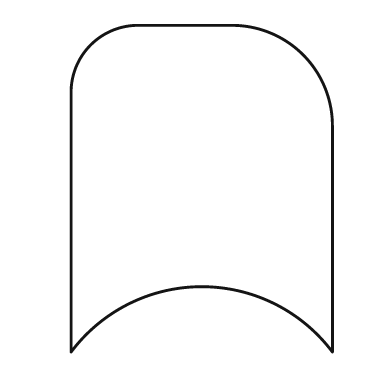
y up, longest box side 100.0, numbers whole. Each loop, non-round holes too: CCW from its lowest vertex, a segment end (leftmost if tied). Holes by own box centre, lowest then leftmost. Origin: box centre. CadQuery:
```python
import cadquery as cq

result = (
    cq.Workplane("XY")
    .moveTo(-40.0, -50.0)
    .threePointArc((0.0, -30.0), (40.0, -50.0))
    .lineTo(40.0, 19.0)
    .threePointArc((31.0, 41.0), (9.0, 50.0))
    .lineTo(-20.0, 50.0)
    .threePointArc((-34.0, 44.0), (-40.0, 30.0))
    .close()
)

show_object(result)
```